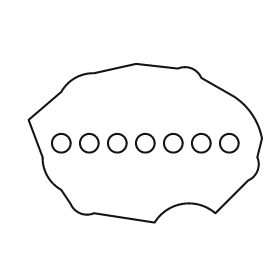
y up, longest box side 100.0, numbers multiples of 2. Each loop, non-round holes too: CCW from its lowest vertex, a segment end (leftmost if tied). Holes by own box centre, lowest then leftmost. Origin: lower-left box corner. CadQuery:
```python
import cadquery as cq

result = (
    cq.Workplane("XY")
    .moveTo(54.0, 0.0)
    .threePointArc((66.0, 8.0), (80.0, 4.0))
    .lineTo(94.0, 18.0)
    .threePointArc((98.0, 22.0), (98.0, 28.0))
    .lineTo(100.0, 36.0)
    .threePointArc((96.0, 46.0), (88.0, 54.0))
    .lineTo(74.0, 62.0)
    .threePointArc((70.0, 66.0), (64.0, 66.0))
    .lineTo(46.0, 68.0)
    .lineTo(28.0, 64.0)
    .threePointArc((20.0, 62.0), (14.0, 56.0))
    .lineTo(0.0, 44.0)
    .lineTo(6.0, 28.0)
    .threePointArc((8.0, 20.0), (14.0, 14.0))
    .lineTo(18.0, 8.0)
    .threePointArc((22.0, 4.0), (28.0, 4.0))
    .close()
    .moveTo(14.0, 34.0)
    .circle(4.0)
    .moveTo(26.0, 34.0)
    .circle(4.0)
    .moveTo(38.0, 34.0)
    .circle(4.0)
    .moveTo(50.0, 34.0)
    .circle(4.0)
    .moveTo(62.0, 34.0)
    .circle(4.0)
    .moveTo(74.0, 34.0)
    .circle(4.0)
    .moveTo(86.0, 34.0)
    .circle(4.0)
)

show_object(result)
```